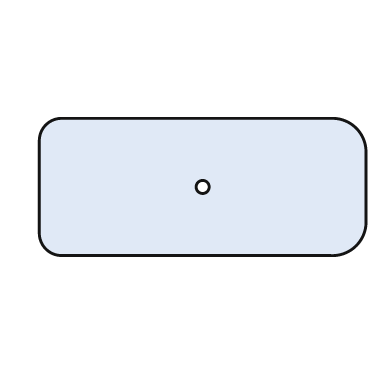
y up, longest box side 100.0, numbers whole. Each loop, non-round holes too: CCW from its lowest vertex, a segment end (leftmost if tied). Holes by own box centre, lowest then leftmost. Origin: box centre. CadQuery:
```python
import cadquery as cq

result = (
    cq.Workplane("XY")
    .moveTo(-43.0, -21.0)
    .lineTo(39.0, -21.0)
    .threePointArc((47.0, -18.0), (50.0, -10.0))
    .lineTo(50.0, 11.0)
    .threePointArc((47.0, 18.0), (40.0, 21.0))
    .lineTo(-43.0, 21.0)
    .threePointArc((-48.0, 19.0), (-50.0, 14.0))
    .lineTo(-50.0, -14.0)
    .threePointArc((-48.0, -19.0), (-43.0, -21.0))
    .close()
    .moveTo(0.0, 0.0)
    .circle(2.0)
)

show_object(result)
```